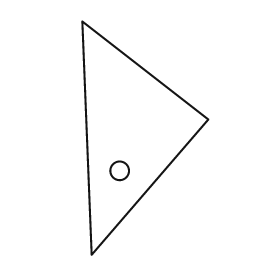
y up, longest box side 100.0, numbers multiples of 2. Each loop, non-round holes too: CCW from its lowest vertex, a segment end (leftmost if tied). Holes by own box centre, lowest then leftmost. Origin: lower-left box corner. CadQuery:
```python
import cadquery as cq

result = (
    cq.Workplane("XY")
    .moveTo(4.0, 0.0)
    .lineTo(54.0, 58.0)
    .lineTo(0.0, 100.0)
    .close()
    .moveTo(16.0, 36.0)
    .circle(4.0)
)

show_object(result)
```